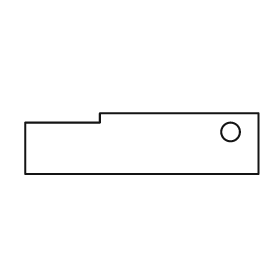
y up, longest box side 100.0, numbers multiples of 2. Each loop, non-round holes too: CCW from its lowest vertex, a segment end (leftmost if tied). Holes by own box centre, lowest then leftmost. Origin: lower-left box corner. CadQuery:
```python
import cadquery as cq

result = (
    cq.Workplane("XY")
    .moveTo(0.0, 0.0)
    .lineTo(100.0, 0.0)
    .lineTo(100.0, 26.0)
    .lineTo(32.0, 26.0)
    .lineTo(32.0, 22.0)
    .lineTo(0.0, 22.0)
    .close()
    .moveTo(88.0, 18.0)
    .circle(4.0)
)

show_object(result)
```